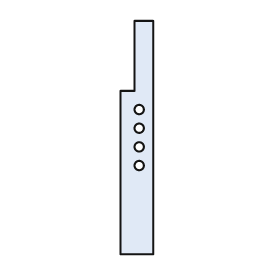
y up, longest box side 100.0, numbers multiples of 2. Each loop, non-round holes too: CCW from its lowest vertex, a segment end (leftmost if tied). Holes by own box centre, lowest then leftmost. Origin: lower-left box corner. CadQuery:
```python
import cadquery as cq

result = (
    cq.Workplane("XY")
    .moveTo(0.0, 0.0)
    .lineTo(14.0, 0.0)
    .lineTo(14.0, 100.0)
    .lineTo(6.0, 100.0)
    .lineTo(6.0, 70.0)
    .lineTo(0.0, 70.0)
    .close()
    .moveTo(8.0, 38.0)
    .circle(2.0)
    .moveTo(8.0, 46.0)
    .circle(2.0)
    .moveTo(8.0, 54.0)
    .circle(2.0)
    .moveTo(8.0, 62.0)
    .circle(2.0)
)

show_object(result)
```